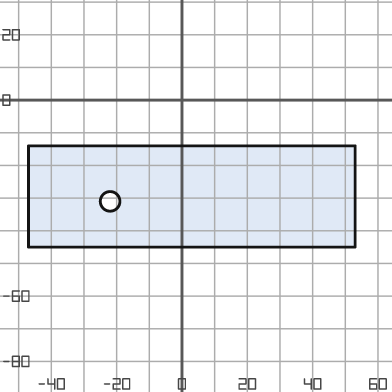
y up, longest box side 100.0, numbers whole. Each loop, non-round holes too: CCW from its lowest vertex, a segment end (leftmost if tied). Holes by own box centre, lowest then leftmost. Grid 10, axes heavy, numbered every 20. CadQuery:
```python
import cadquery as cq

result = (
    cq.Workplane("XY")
    .moveTo(-47.0, -45.0)
    .lineTo(53.0, -45.0)
    .lineTo(53.0, -14.0)
    .lineTo(-47.0, -14.0)
    .close()
    .moveTo(-22.0, -31.0)
    .circle(3.0)
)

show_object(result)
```